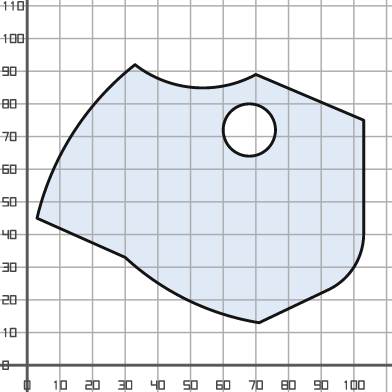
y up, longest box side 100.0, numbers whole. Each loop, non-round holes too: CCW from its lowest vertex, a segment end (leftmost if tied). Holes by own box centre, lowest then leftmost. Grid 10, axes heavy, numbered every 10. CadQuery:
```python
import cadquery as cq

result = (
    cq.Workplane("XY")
    .moveTo(71.0, 13.0)
    .lineTo(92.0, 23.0)
    .threePointArc((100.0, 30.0), (103.0, 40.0))
    .lineTo(103.0, 75.0)
    .lineTo(70.0, 89.0)
    .threePointArc((51.0, 85.0), (33.0, 92.0))
    .threePointArc((14.0, 71.0), (3.0, 45.0))
    .lineTo(30.0, 33.0)
    .threePointArc((49.0, 20.0), (71.0, 13.0))
    .close()
    .moveTo(68.0, 72.0)
    .circle(8.0)
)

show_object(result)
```